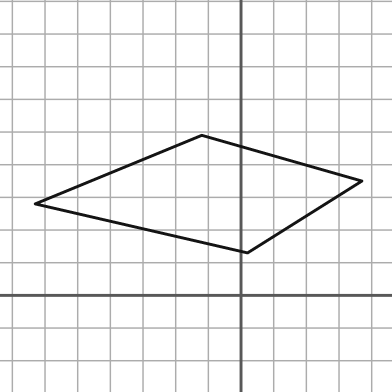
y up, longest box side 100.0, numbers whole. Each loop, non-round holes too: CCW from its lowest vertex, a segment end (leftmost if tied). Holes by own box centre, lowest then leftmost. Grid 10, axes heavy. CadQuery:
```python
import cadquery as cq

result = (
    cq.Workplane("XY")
    .moveTo(2.0, 13.0)
    .lineTo(37.0, 35.0)
    .lineTo(-12.0, 49.0)
    .lineTo(-63.0, 28.0)
    .close()
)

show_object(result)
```